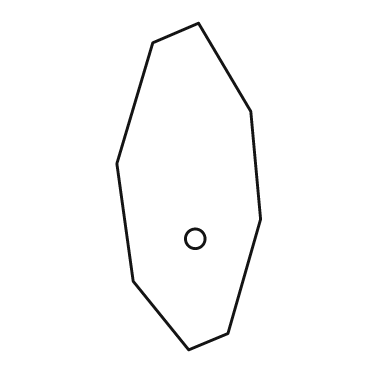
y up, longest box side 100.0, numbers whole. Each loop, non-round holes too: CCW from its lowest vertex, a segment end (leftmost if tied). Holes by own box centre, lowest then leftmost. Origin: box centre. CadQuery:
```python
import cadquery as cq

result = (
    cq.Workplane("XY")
    .moveTo(0.0, -50.0)
    .lineTo(12.0, -45.0)
    .lineTo(22.0, -10.0)
    .lineTo(19.0, 23.0)
    .lineTo(3.0, 50.0)
    .lineTo(-11.0, 44.0)
    .lineTo(-22.0, 7.0)
    .lineTo(-17.0, -29.0)
    .close()
    .moveTo(2.0, -16.0)
    .circle(3.0)
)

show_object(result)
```